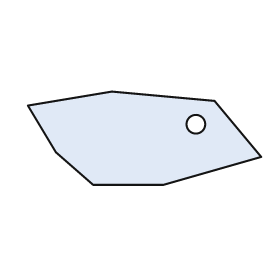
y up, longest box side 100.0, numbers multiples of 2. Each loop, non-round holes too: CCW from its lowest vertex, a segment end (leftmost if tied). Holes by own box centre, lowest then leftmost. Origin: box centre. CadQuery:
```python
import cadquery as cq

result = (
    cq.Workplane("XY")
    .moveTo(-22.0, -20.0)
    .lineTo(8.0, -20.0)
    .lineTo(50.0, -8.0)
    .lineTo(30.0, 16.0)
    .lineTo(-14.0, 20.0)
    .lineTo(-50.0, 14.0)
    .lineTo(-38.0, -6.0)
    .close()
    .moveTo(22.0, 6.0)
    .circle(4.0)
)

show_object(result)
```